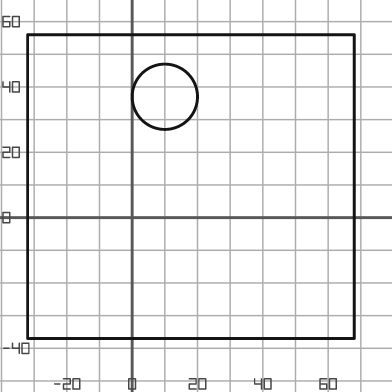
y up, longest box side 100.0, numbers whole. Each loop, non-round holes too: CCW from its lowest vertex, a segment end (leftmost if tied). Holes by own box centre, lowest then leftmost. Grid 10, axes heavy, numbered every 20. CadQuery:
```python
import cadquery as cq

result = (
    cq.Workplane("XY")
    .moveTo(-32.0, -37.0)
    .lineTo(68.0, -37.0)
    .lineTo(68.0, 56.0)
    .lineTo(-32.0, 56.0)
    .close()
    .moveTo(10.0, 37.0)
    .circle(10.0)
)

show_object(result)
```